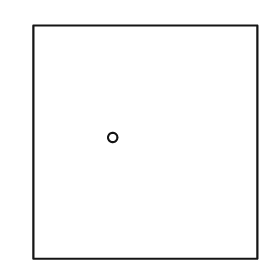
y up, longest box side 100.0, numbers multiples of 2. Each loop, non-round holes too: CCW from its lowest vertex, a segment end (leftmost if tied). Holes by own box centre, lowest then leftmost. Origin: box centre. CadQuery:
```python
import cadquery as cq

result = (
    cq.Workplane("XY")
    .moveTo(-48.0, -50.0)
    .lineTo(48.0, -50.0)
    .lineTo(48.0, 50.0)
    .lineTo(-48.0, 50.0)
    .close()
    .moveTo(-14.0, 2.0)
    .circle(2.0)
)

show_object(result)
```